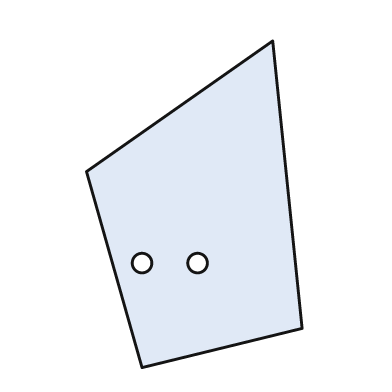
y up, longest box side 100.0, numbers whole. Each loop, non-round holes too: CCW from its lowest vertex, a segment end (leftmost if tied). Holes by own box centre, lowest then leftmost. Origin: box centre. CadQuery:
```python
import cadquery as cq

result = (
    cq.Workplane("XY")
    .moveTo(-16.0, -50.0)
    .lineTo(33.0, -38.0)
    .lineTo(24.0, 50.0)
    .lineTo(-33.0, 10.0)
    .close()
    .moveTo(-16.0, -18.0)
    .circle(3.0)
    .moveTo(1.0, -18.0)
    .circle(3.0)
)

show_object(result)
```